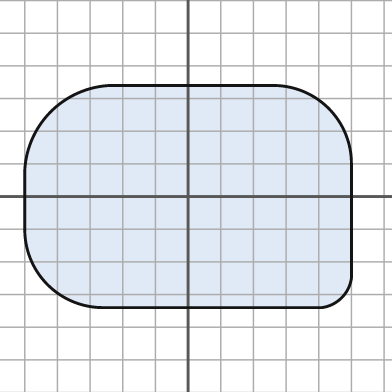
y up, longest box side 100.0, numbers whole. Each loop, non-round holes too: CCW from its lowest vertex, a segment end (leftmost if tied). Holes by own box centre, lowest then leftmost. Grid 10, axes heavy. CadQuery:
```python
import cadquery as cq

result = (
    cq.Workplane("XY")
    .moveTo(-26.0, -34.0)
    .lineTo(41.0, -34.0)
    .threePointArc((47.0, -31.0), (50.0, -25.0))
    .lineTo(50.0, 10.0)
    .threePointArc((43.0, 27.0), (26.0, 34.0))
    .lineTo(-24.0, 34.0)
    .threePointArc((-42.0, 26.0), (-50.0, 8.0))
    .lineTo(-50.0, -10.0)
    .threePointArc((-43.0, -27.0), (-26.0, -34.0))
    .close()
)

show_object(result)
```